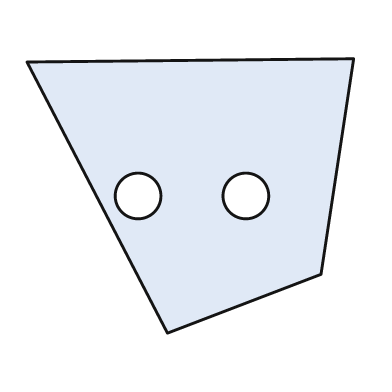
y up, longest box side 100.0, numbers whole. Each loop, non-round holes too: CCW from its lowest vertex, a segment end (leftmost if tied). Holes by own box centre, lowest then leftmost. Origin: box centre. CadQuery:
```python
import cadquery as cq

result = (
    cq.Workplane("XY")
    .moveTo(-7.0, -42.0)
    .lineTo(40.0, -24.0)
    .lineTo(50.0, 42.0)
    .lineTo(-50.0, 41.0)
    .close()
    .moveTo(-16.0, 0.0)
    .circle(7.0)
    .moveTo(17.0, 0.0)
    .circle(7.0)
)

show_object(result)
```